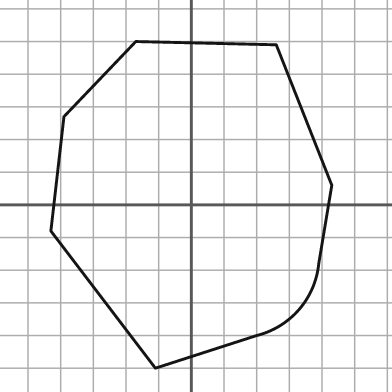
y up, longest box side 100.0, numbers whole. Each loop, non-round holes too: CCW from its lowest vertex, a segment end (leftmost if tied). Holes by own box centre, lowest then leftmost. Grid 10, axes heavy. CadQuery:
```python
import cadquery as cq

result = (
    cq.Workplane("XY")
    .moveTo(-11.0, -50.0)
    .lineTo(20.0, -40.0)
    .threePointArc((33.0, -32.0), (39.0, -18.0))
    .lineTo(43.0, 6.0)
    .lineTo(26.0, 49.0)
    .lineTo(-17.0, 50.0)
    .lineTo(-39.0, 27.0)
    .lineTo(-43.0, -8.0)
    .close()
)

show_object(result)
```